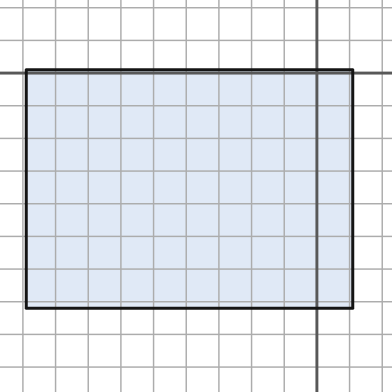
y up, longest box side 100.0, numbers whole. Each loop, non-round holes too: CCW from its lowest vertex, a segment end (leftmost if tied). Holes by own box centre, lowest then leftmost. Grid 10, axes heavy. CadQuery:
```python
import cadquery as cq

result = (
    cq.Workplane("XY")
    .moveTo(-89.0, -72.0)
    .lineTo(11.0, -72.0)
    .lineTo(11.0, 1.0)
    .lineTo(-89.0, 1.0)
    .close()
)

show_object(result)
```